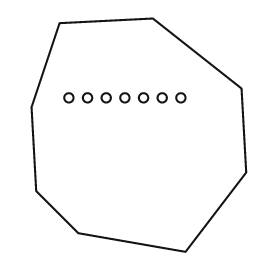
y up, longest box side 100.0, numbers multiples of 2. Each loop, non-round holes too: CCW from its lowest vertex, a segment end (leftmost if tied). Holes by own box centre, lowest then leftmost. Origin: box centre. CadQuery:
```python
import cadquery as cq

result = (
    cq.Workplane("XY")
    .moveTo(20.0, -50.0)
    .lineTo(46.0, -16.0)
    .lineTo(44.0, 20.0)
    .lineTo(6.0, 50.0)
    .lineTo(-34.0, 48.0)
    .lineTo(-46.0, 12.0)
    .lineTo(-44.0, -24.0)
    .lineTo(-26.0, -42.0)
    .close()
    .moveTo(-30.0, 16.0)
    .circle(2.0)
    .moveTo(-22.0, 16.0)
    .circle(2.0)
    .moveTo(-14.0, 16.0)
    .circle(2.0)
    .moveTo(-6.0, 16.0)
    .circle(2.0)
    .moveTo(2.0, 16.0)
    .circle(2.0)
    .moveTo(10.0, 16.0)
    .circle(2.0)
    .moveTo(18.0, 16.0)
    .circle(2.0)
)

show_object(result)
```